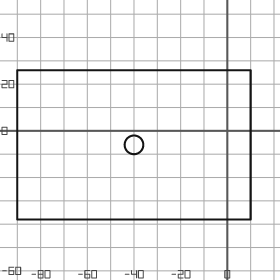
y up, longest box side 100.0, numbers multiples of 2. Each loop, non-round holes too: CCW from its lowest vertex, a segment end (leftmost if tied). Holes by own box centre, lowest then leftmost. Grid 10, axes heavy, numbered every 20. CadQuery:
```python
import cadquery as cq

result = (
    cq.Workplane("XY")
    .moveTo(-90.0, -38.0)
    .lineTo(10.0, -38.0)
    .lineTo(10.0, 26.0)
    .lineTo(-90.0, 26.0)
    .close()
    .moveTo(-40.0, -6.0)
    .circle(4.0)
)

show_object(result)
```